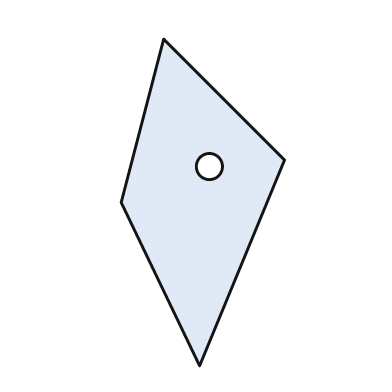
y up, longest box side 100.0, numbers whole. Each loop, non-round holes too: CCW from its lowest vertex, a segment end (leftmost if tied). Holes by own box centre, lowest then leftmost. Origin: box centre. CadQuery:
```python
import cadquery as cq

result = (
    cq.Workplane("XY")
    .moveTo(-1.0, -50.0)
    .lineTo(25.0, 13.0)
    .lineTo(-12.0, 50.0)
    .lineTo(-25.0, 0.0)
    .close()
    .moveTo(2.0, 11.0)
    .circle(4.0)
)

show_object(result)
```